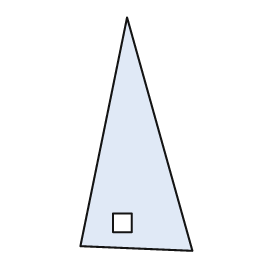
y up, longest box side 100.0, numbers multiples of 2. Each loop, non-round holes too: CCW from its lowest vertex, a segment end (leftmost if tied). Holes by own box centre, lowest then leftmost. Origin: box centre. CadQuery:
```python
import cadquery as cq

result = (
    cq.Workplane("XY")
    .moveTo(24.0, -50.0)
    .lineTo(-4.0, 50.0)
    .lineTo(-24.0, -48.0)
    .close()
    .moveTo(-10.0, -42.0)
    .lineTo(-2.0, -42.0)
    .lineTo(-2.0, -34.0)
    .lineTo(-10.0, -34.0)
    .close()
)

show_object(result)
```